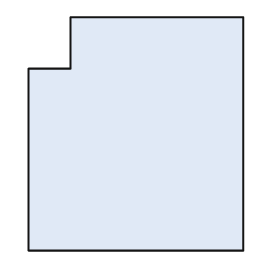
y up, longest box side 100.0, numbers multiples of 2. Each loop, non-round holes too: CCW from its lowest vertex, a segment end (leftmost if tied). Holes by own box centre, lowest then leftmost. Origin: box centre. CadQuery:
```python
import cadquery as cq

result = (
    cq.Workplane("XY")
    .moveTo(-46.0, -50.0)
    .lineTo(46.0, -50.0)
    .lineTo(46.0, 50.0)
    .lineTo(-28.0, 50.0)
    .lineTo(-28.0, 28.0)
    .lineTo(-46.0, 28.0)
    .close()
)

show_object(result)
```